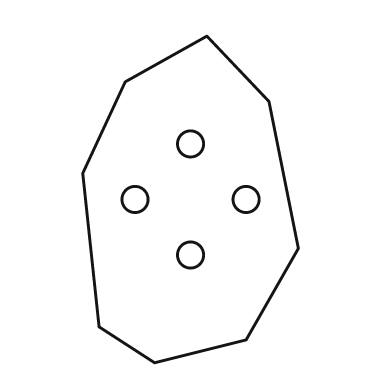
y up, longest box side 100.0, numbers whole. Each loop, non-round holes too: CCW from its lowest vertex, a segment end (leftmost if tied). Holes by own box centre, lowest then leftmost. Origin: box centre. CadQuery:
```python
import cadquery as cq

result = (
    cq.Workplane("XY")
    .moveTo(-11.0, -50.0)
    .lineTo(17.0, -43.0)
    .lineTo(33.0, -15.0)
    .lineTo(24.0, 30.0)
    .lineTo(5.0, 50.0)
    .lineTo(-20.0, 36.0)
    .lineTo(-33.0, 8.0)
    .lineTo(-28.0, -39.0)
    .close()
    .moveTo(0.0, -17.0)
    .circle(4.0)
    .moveTo(-17.0, 0.0)
    .circle(4.0)
    .moveTo(17.0, 0.0)
    .circle(4.0)
    .moveTo(0.0, 17.0)
    .circle(4.0)
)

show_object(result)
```